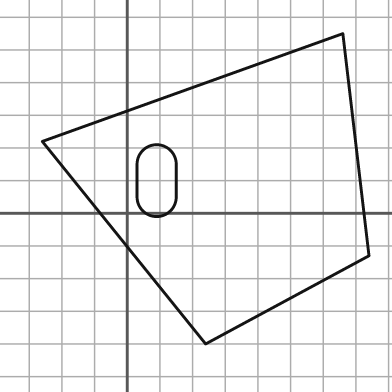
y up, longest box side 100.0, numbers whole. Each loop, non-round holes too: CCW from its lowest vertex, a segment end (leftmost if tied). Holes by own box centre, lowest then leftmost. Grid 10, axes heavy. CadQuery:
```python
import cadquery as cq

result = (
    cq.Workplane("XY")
    .moveTo(24.0, -40.0)
    .lineTo(74.0, -13.0)
    .lineTo(66.0, 55.0)
    .lineTo(-26.0, 22.0)
    .close()
    .moveTo(3.0, 5.0)
    .threePointArc((9.0, -1.0), (15.0, 5.0))
    .lineTo(15.0, 15.0)
    .threePointArc((9.0, 21.0), (3.0, 15.0))
    .close()
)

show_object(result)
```